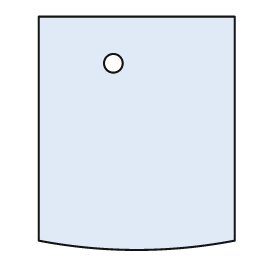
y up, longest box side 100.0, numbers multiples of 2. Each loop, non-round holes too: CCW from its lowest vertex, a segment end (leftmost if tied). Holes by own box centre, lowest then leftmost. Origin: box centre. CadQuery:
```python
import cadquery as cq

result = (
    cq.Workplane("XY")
    .moveTo(-42.0, -46.0)
    .threePointArc((0.0, -50.0), (42.0, -46.0))
    .lineTo(42.0, 50.0)
    .lineTo(-42.0, 50.0)
    .close()
    .moveTo(-10.0, 30.0)
    .circle(4.0)
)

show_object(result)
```